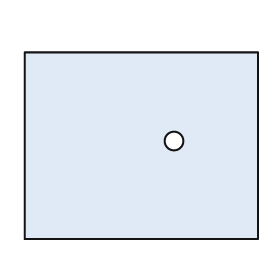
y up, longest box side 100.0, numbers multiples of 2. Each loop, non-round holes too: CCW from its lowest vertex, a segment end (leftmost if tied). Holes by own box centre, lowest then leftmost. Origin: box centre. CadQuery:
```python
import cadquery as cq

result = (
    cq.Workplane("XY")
    .moveTo(-50.0, -40.0)
    .lineTo(50.0, -40.0)
    .lineTo(50.0, 40.0)
    .lineTo(-50.0, 40.0)
    .close()
    .moveTo(14.0, 2.0)
    .circle(4.0)
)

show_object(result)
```